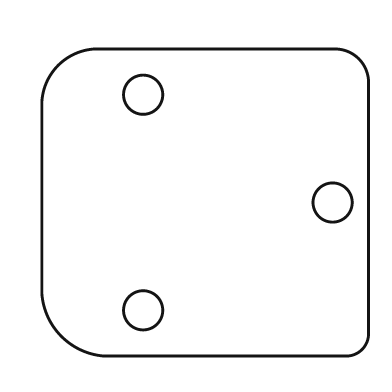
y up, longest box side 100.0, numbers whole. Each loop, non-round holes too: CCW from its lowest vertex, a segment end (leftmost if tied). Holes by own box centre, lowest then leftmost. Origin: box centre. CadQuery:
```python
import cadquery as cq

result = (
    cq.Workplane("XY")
    .moveTo(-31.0, -47.0)
    .lineTo(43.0, -47.0)
    .threePointArc((48.0, -45.0), (50.0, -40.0))
    .lineTo(50.0, 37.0)
    .threePointArc((47.0, 44.0), (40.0, 47.0))
    .lineTo(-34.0, 47.0)
    .threePointArc((-45.0, 42.0), (-50.0, 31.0))
    .lineTo(-50.0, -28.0)
    .threePointArc((-44.0, -41.0), (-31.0, -47.0))
    .close()
    .moveTo(-19.0, -33.0)
    .circle(6.0)
    .moveTo(39.0, 0.0)
    .circle(6.0)
    .moveTo(-19.0, 33.0)
    .circle(6.0)
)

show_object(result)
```